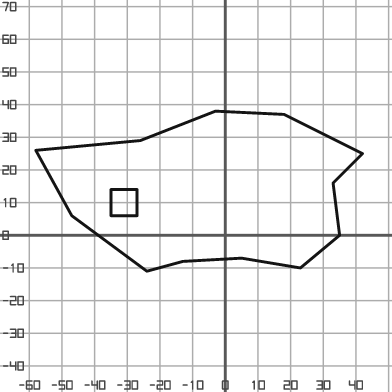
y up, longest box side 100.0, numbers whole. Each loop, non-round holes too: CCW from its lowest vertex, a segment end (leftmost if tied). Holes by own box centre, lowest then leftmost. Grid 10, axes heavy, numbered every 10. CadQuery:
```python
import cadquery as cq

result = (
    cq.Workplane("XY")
    .moveTo(-24.0, -11.0)
    .lineTo(-13.0, -8.0)
    .lineTo(5.0, -7.0)
    .lineTo(23.0, -10.0)
    .lineTo(35.0, 0.0)
    .lineTo(33.0, 16.0)
    .lineTo(42.0, 25.0)
    .lineTo(18.0, 37.0)
    .lineTo(-3.0, 38.0)
    .lineTo(-26.0, 29.0)
    .lineTo(-58.0, 26.0)
    .lineTo(-47.0, 6.0)
    .close()
    .moveTo(-35.0, 6.0)
    .lineTo(-27.0, 6.0)
    .lineTo(-27.0, 14.0)
    .lineTo(-35.0, 14.0)
    .close()
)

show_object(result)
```